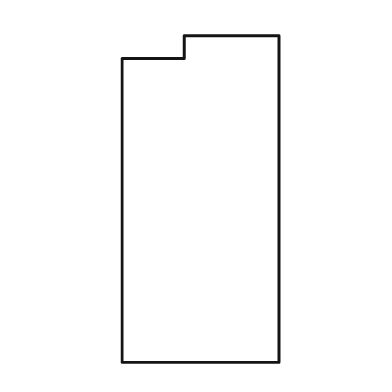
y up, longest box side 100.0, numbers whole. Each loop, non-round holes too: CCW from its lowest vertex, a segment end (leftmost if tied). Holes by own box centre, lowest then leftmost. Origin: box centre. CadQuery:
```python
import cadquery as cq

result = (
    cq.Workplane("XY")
    .moveTo(-24.0, -50.0)
    .lineTo(24.0, -50.0)
    .lineTo(24.0, 50.0)
    .lineTo(-5.0, 50.0)
    .lineTo(-5.0, 43.0)
    .lineTo(-24.0, 43.0)
    .close()
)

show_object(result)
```